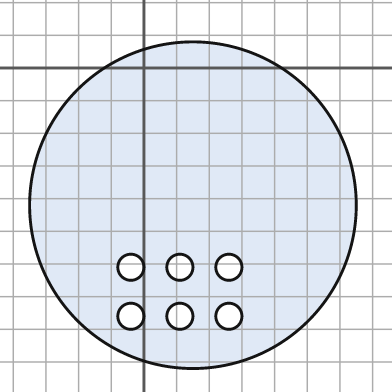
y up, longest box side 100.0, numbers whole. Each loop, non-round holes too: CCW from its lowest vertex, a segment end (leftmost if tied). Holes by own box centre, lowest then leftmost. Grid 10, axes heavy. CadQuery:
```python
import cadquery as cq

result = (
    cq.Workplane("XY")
    .moveTo(15.0, -42.0)
    .circle(50.0)
    .moveTo(-4.0, -76.0)
    .circle(4.0)
    .moveTo(11.0, -76.0)
    .circle(4.0)
    .moveTo(26.0, -76.0)
    .circle(4.0)
    .moveTo(-4.0, -61.0)
    .circle(4.0)
    .moveTo(11.0, -61.0)
    .circle(4.0)
    .moveTo(26.0, -61.0)
    .circle(4.0)
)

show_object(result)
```